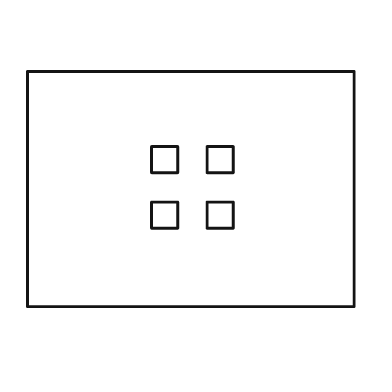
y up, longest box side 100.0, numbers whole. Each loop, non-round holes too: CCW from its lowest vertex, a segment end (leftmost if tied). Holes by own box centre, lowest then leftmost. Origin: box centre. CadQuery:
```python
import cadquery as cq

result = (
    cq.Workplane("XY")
    .moveTo(-50.0, -36.0)
    .lineTo(50.0, -36.0)
    .lineTo(50.0, 36.0)
    .lineTo(-50.0, 36.0)
    .close()
    .moveTo(-12.0, -12.0)
    .lineTo(-4.0, -12.0)
    .lineTo(-4.0, -4.0)
    .lineTo(-12.0, -4.0)
    .close()
    .moveTo(5.0, -12.0)
    .lineTo(13.0, -12.0)
    .lineTo(13.0, -4.0)
    .lineTo(5.0, -4.0)
    .close()
    .moveTo(-12.0, 5.0)
    .lineTo(-4.0, 5.0)
    .lineTo(-4.0, 13.0)
    .lineTo(-12.0, 13.0)
    .close()
    .moveTo(5.0, 5.0)
    .lineTo(13.0, 5.0)
    .lineTo(13.0, 13.0)
    .lineTo(5.0, 13.0)
    .close()
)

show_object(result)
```